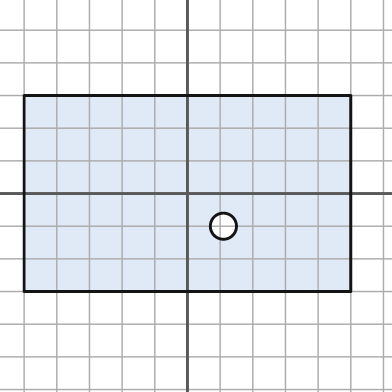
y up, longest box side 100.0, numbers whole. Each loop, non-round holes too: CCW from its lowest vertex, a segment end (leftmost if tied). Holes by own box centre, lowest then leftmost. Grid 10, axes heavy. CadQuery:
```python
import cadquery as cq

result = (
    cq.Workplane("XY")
    .moveTo(-50.0, -30.0)
    .lineTo(50.0, -30.0)
    .lineTo(50.0, 30.0)
    .lineTo(-50.0, 30.0)
    .close()
    .moveTo(11.0, -10.0)
    .circle(4.0)
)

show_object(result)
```